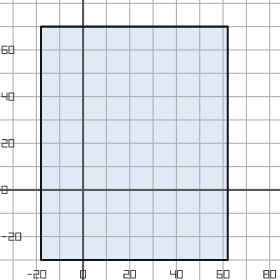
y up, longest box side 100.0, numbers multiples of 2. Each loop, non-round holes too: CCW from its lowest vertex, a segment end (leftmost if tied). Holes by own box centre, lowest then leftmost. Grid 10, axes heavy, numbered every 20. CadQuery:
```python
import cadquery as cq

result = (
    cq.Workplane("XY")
    .moveTo(-18.0, -30.0)
    .lineTo(62.0, -30.0)
    .lineTo(62.0, 70.0)
    .lineTo(-18.0, 70.0)
    .close()
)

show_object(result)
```